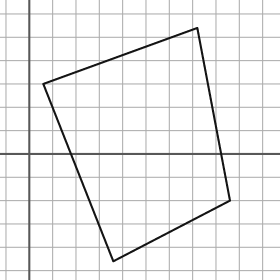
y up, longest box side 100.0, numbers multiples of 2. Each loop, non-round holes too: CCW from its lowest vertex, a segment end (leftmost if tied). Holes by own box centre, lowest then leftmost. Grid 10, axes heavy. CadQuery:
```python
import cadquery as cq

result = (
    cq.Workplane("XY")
    .moveTo(36.0, -46.0)
    .lineTo(86.0, -20.0)
    .lineTo(72.0, 54.0)
    .lineTo(6.0, 30.0)
    .close()
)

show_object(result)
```